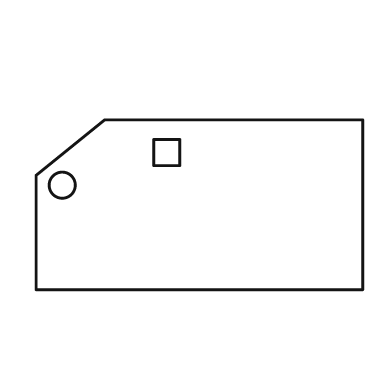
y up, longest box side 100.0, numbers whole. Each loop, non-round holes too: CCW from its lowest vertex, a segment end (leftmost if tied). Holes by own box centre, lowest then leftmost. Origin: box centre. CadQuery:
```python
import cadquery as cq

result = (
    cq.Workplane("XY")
    .moveTo(-50.0, -26.0)
    .lineTo(50.0, -26.0)
    .lineTo(50.0, 26.0)
    .lineTo(-29.0, 26.0)
    .lineTo(-50.0, 9.0)
    .close()
    .moveTo(-42.0, 6.0)
    .circle(4.0)
    .moveTo(-14.0, 12.0)
    .lineTo(-6.0, 12.0)
    .lineTo(-6.0, 20.0)
    .lineTo(-14.0, 20.0)
    .close()
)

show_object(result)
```